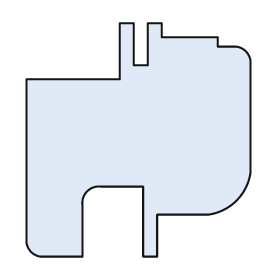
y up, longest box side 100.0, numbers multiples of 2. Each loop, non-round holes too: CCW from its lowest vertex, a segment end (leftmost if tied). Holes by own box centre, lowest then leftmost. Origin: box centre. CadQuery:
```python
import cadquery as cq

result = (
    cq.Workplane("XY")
    .moveTo(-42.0, -50.0)
    .lineTo(-24.0, -50.0)
    .lineTo(-24.0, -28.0)
    .threePointArc((-22.0, -22.0), (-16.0, -20.0))
    .lineTo(2.0, -20.0)
    .lineTo(2.0, -50.0)
    .lineTo(8.0, -50.0)
    .lineTo(8.0, -32.0)
    .lineTo(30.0, -32.0)
    .threePointArc((42.0, -26.0), (48.0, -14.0))
    .lineTo(48.0, 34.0)
    .threePointArc((46.0, 38.0), (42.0, 40.0))
    .lineTo(34.0, 40.0)
    .lineTo(34.0, 44.0)
    .lineTo(10.0, 44.0)
    .lineTo(10.0, 50.0)
    .lineTo(4.0, 50.0)
    .lineTo(4.0, 32.0)
    .lineTo(-2.0, 32.0)
    .lineTo(-2.0, 50.0)
    .lineTo(-8.0, 50.0)
    .lineTo(-8.0, 26.0)
    .lineTo(-48.0, 26.0)
    .lineTo(-48.0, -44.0)
    .threePointArc((-46.0, -48.0), (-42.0, -50.0))
    .close()
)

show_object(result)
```